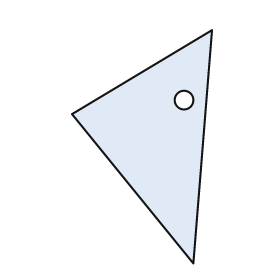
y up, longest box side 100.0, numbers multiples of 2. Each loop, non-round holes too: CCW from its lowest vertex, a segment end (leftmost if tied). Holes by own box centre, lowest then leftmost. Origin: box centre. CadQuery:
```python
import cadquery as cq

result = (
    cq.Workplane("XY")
    .moveTo(22.0, -50.0)
    .lineTo(30.0, 50.0)
    .lineTo(-30.0, 14.0)
    .close()
    .moveTo(18.0, 20.0)
    .circle(4.0)
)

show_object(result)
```